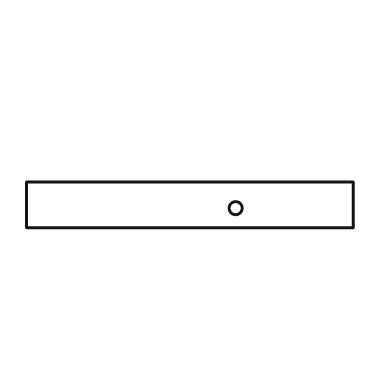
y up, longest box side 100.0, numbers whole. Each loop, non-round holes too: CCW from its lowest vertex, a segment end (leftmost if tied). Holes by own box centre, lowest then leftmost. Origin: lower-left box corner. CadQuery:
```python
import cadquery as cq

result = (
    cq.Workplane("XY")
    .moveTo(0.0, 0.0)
    .lineTo(100.0, 0.0)
    .lineTo(100.0, 14.0)
    .lineTo(0.0, 14.0)
    .close()
    .moveTo(64.0, 6.0)
    .circle(2.0)
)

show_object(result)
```